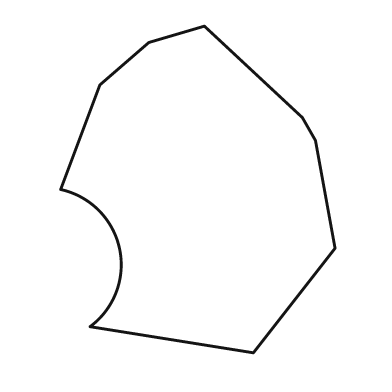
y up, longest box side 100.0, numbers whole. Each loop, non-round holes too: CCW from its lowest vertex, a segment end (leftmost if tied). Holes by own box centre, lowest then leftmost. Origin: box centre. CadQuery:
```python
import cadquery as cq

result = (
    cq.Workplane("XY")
    .moveTo(17.0, -50.0)
    .lineTo(42.0, -18.0)
    .lineTo(36.0, 15.0)
    .lineTo(32.0, 22.0)
    .lineTo(2.0, 50.0)
    .lineTo(-15.0, 45.0)
    .lineTo(-30.0, 32.0)
    .lineTo(-42.0, 0.0)
    .threePointArc((-24.0, -18.0), (-33.0, -42.0))
    .close()
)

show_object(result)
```